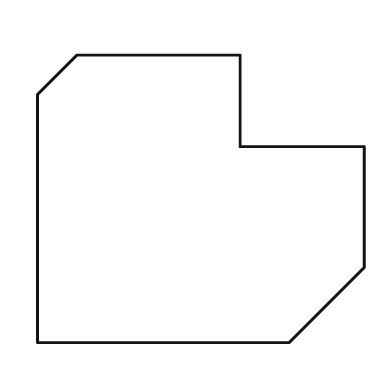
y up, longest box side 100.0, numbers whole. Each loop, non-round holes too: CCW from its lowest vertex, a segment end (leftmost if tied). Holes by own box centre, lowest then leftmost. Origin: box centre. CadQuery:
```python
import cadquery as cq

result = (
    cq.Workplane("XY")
    .moveTo(-50.0, -44.0)
    .lineTo(27.0, -44.0)
    .lineTo(50.0, -21.0)
    .lineTo(50.0, 16.0)
    .lineTo(12.0, 16.0)
    .lineTo(12.0, 44.0)
    .lineTo(-38.0, 44.0)
    .lineTo(-50.0, 32.0)
    .close()
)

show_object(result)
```